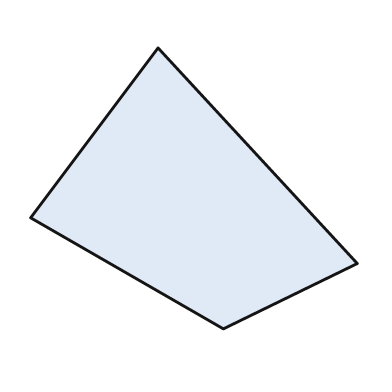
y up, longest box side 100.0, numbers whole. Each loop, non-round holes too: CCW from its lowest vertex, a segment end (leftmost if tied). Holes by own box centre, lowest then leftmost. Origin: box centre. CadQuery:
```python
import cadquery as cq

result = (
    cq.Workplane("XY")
    .moveTo(9.0, -43.0)
    .lineTo(50.0, -23.0)
    .lineTo(-11.0, 43.0)
    .lineTo(-50.0, -9.0)
    .close()
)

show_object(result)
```